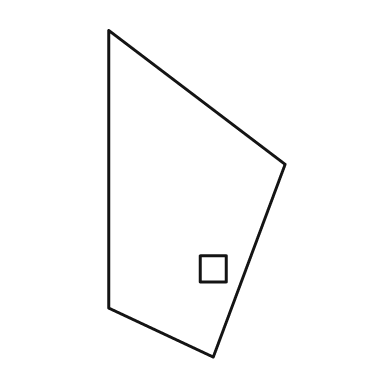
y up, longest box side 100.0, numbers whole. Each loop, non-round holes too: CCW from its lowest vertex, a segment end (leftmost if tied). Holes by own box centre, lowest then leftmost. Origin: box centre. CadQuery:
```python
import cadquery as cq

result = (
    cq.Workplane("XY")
    .moveTo(5.0, -50.0)
    .lineTo(27.0, 9.0)
    .lineTo(-27.0, 50.0)
    .lineTo(-27.0, -35.0)
    .close()
    .moveTo(1.0, -27.0)
    .lineTo(9.0, -27.0)
    .lineTo(9.0, -19.0)
    .lineTo(1.0, -19.0)
    .close()
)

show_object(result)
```